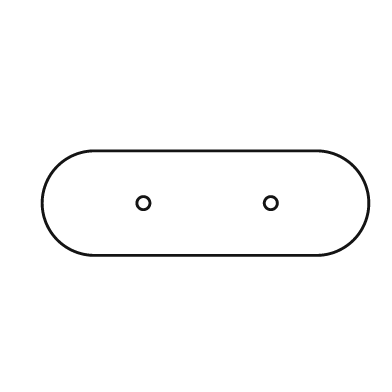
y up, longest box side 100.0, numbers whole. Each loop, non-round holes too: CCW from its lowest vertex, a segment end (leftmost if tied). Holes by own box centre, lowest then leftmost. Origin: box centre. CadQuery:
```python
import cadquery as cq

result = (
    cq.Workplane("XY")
    .moveTo(-34.0, -16.0)
    .lineTo(34.0, -16.0)
    .threePointArc((50.0, 0.0), (34.0, 16.0))
    .lineTo(-34.0, 16.0)
    .threePointArc((-50.0, 0.0), (-34.0, -16.0))
    .close()
    .moveTo(-19.0, 0.0)
    .circle(2.0)
    .moveTo(20.0, 0.0)
    .circle(2.0)
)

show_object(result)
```